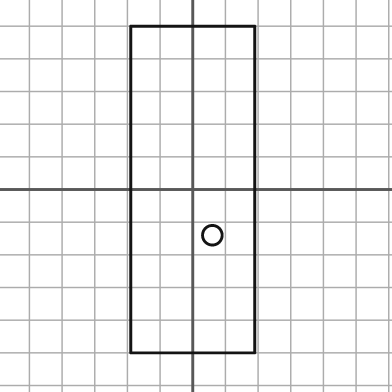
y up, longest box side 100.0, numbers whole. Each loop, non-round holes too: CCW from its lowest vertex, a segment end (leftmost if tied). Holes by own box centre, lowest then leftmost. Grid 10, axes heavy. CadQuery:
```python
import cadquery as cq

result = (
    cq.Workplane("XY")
    .moveTo(-19.0, -50.0)
    .lineTo(19.0, -50.0)
    .lineTo(19.0, 50.0)
    .lineTo(-19.0, 50.0)
    .close()
    .moveTo(6.0, -14.0)
    .circle(3.0)
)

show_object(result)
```